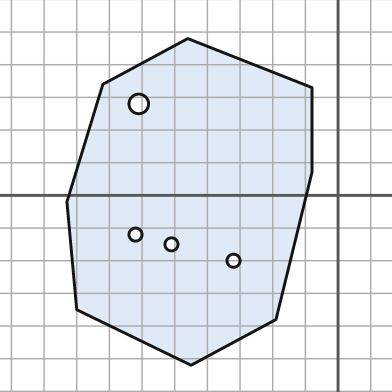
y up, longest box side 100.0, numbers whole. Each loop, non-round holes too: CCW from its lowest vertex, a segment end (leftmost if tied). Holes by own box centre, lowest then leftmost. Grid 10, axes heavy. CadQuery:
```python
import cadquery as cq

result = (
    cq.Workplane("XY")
    .moveTo(-45.0, -52.0)
    .lineTo(-19.0, -38.0)
    .lineTo(-8.0, 7.0)
    .lineTo(-8.0, 33.0)
    .lineTo(-46.0, 48.0)
    .lineTo(-72.0, 34.0)
    .lineTo(-83.0, -2.0)
    .lineTo(-80.0, -35.0)
    .close()
    .moveTo(-32.0, -20.0)
    .circle(2.0)
    .moveTo(-51.0, -15.0)
    .circle(2.0)
    .moveTo(-62.0, -12.0)
    .circle(2.0)
    .moveTo(-61.0, 28.0)
    .circle(3.0)
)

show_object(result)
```